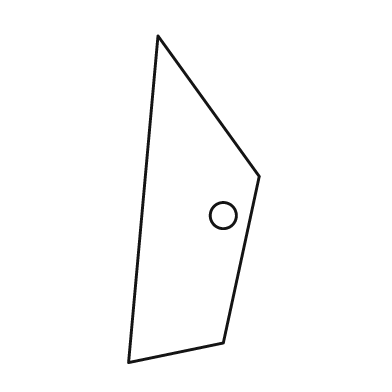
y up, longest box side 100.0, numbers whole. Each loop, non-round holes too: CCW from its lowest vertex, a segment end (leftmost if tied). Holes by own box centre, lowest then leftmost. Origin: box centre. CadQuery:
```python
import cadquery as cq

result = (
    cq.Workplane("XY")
    .moveTo(-20.0, -50.0)
    .lineTo(9.0, -44.0)
    .lineTo(20.0, 7.0)
    .lineTo(-11.0, 50.0)
    .close()
    .moveTo(9.0, -5.0)
    .circle(4.0)
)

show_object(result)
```